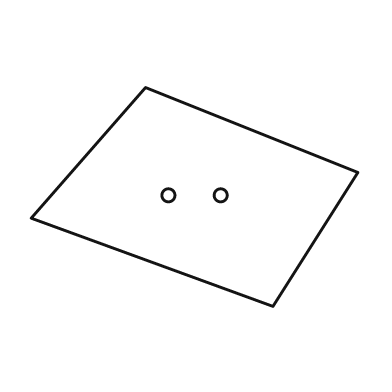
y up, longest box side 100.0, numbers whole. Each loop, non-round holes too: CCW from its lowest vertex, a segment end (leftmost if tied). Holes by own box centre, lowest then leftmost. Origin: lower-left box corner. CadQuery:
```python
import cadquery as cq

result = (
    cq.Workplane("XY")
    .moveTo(74.0, 0.0)
    .lineTo(100.0, 41.0)
    .lineTo(35.0, 67.0)
    .lineTo(0.0, 27.0)
    .close()
    .moveTo(42.0, 34.0)
    .circle(2.0)
    .moveTo(58.0, 34.0)
    .circle(2.0)
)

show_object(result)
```